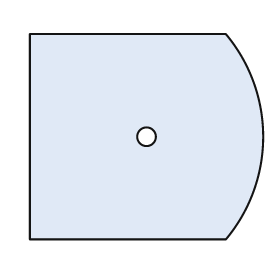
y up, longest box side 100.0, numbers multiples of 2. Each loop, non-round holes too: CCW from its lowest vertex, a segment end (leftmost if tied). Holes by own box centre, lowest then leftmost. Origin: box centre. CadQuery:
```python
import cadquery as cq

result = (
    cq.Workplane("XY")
    .moveTo(-50.0, -44.0)
    .lineTo(34.0, -44.0)
    .threePointArc((50.0, 0.0), (34.0, 44.0))
    .lineTo(-50.0, 44.0)
    .close()
    .moveTo(0.0, 0.0)
    .circle(4.0)
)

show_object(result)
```